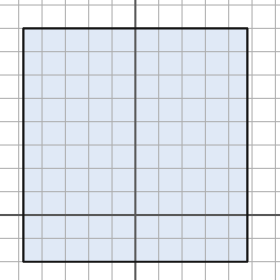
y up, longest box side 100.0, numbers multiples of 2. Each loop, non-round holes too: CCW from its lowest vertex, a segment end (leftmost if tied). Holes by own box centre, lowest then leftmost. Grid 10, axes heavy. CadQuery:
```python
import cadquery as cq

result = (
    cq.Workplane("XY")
    .moveTo(-48.0, -20.0)
    .lineTo(48.0, -20.0)
    .lineTo(48.0, 80.0)
    .lineTo(-48.0, 80.0)
    .close()
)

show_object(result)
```